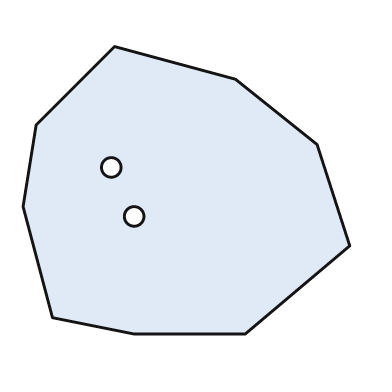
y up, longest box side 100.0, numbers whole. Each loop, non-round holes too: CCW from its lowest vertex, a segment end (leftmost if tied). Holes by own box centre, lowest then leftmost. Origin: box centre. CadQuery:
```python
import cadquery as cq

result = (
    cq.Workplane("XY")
    .moveTo(-16.0, -44.0)
    .lineTo(18.0, -44.0)
    .lineTo(50.0, -17.0)
    .lineTo(40.0, 14.0)
    .lineTo(15.0, 34.0)
    .lineTo(-22.0, 44.0)
    .lineTo(-46.0, 20.0)
    .lineTo(-50.0, -5.0)
    .lineTo(-41.0, -39.0)
    .close()
    .moveTo(-16.0, -8.0)
    .circle(3.0)
    .moveTo(-23.0, 7.0)
    .circle(3.0)
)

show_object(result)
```